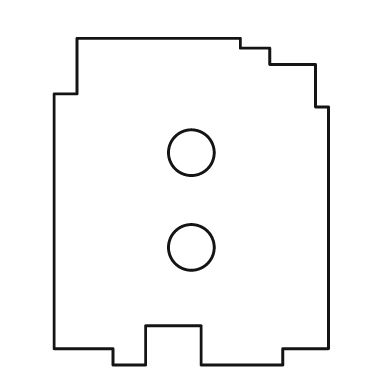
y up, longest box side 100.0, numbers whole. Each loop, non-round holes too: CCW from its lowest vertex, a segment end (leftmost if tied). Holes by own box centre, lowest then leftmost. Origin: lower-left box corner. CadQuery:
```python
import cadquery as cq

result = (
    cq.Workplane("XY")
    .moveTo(18.0, 0.0)
    .lineTo(28.0, 0.0)
    .lineTo(28.0, 12.0)
    .lineTo(45.0, 12.0)
    .lineTo(45.0, 0.0)
    .lineTo(70.0, 0.0)
    .lineTo(70.0, 5.0)
    .lineTo(84.0, 5.0)
    .lineTo(84.0, 79.0)
    .lineTo(80.0, 79.0)
    .lineTo(80.0, 92.0)
    .lineTo(66.0, 92.0)
    .lineTo(66.0, 97.0)
    .lineTo(57.0, 97.0)
    .lineTo(57.0, 100.0)
    .lineTo(7.0, 100.0)
    .lineTo(7.0, 83.0)
    .lineTo(0.0, 83.0)
    .lineTo(0.0, 5.0)
    .lineTo(18.0, 5.0)
    .close()
    .moveTo(42.0, 36.0)
    .circle(7.0)
    .moveTo(42.0, 65.0)
    .circle(7.0)
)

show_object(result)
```